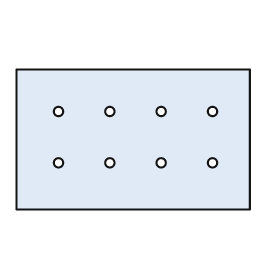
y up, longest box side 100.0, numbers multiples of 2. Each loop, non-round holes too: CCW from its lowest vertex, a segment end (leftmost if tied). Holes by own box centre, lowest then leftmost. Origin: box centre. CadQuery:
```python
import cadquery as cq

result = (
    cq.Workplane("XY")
    .moveTo(-50.0, -30.0)
    .lineTo(50.0, -30.0)
    .lineTo(50.0, 30.0)
    .lineTo(-50.0, 30.0)
    .close()
    .moveTo(-32.0, -10.0)
    .circle(2.0)
    .moveTo(-10.0, -10.0)
    .circle(2.0)
    .moveTo(12.0, -10.0)
    .circle(2.0)
    .moveTo(34.0, -10.0)
    .circle(2.0)
    .moveTo(-32.0, 12.0)
    .circle(2.0)
    .moveTo(-10.0, 12.0)
    .circle(2.0)
    .moveTo(12.0, 12.0)
    .circle(2.0)
    .moveTo(34.0, 12.0)
    .circle(2.0)
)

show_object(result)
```